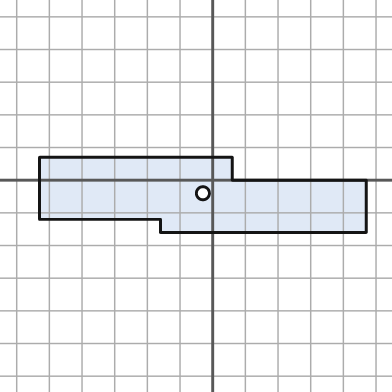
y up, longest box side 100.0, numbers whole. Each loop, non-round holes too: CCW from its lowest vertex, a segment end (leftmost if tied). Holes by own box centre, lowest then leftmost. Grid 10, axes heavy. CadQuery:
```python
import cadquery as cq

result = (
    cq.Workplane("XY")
    .moveTo(-16.0, -16.0)
    .lineTo(47.0, -16.0)
    .lineTo(47.0, 0.0)
    .lineTo(6.0, 0.0)
    .lineTo(6.0, 7.0)
    .lineTo(-53.0, 7.0)
    .lineTo(-53.0, -12.0)
    .lineTo(-16.0, -12.0)
    .close()
    .moveTo(-3.0, -4.0)
    .circle(2.0)
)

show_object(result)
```